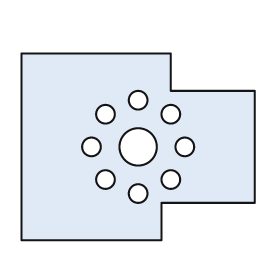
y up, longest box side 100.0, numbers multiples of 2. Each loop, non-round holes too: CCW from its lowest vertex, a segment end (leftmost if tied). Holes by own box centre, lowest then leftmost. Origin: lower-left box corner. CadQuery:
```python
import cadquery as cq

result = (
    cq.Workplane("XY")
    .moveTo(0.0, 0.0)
    .lineTo(60.0, 0.0)
    .lineTo(60.0, 16.0)
    .lineTo(100.0, 16.0)
    .lineTo(100.0, 64.0)
    .lineTo(64.0, 64.0)
    .lineTo(64.0, 80.0)
    .lineTo(0.0, 80.0)
    .close()
    .moveTo(50.0, 20.0)
    .circle(4.0)
    .moveTo(36.0, 26.0)
    .circle(4.0)
    .moveTo(64.0, 26.0)
    .circle(4.0)
    .moveTo(30.0, 40.0)
    .circle(4.0)
    .moveTo(50.0, 40.0)
    .circle(8.0)
    .moveTo(70.0, 40.0)
    .circle(4.0)
    .moveTo(36.0, 54.0)
    .circle(4.0)
    .moveTo(64.0, 54.0)
    .circle(4.0)
    .moveTo(50.0, 60.0)
    .circle(4.0)
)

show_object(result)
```